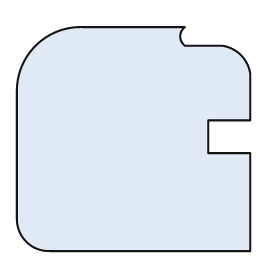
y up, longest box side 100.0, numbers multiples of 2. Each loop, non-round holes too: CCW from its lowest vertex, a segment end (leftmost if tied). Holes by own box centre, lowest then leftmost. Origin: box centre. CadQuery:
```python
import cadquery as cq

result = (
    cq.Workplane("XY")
    .moveTo(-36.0, -48.0)
    .lineTo(50.0, -48.0)
    .lineTo(50.0, -6.0)
    .lineTo(32.0, -6.0)
    .lineTo(32.0, 8.0)
    .lineTo(50.0, 8.0)
    .lineTo(50.0, 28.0)
    .threePointArc((46.0, 36.0), (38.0, 40.0))
    .lineTo(22.0, 40.0)
    .threePointArc((20.0, 44.0), (22.0, 48.0))
    .lineTo(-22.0, 48.0)
    .threePointArc((-42.0, 40.0), (-50.0, 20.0))
    .lineTo(-50.0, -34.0)
    .threePointArc((-46.0, -44.0), (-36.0, -48.0))
    .close()
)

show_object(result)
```